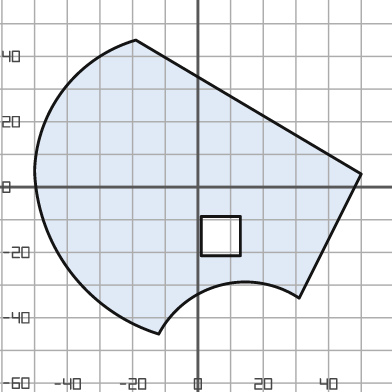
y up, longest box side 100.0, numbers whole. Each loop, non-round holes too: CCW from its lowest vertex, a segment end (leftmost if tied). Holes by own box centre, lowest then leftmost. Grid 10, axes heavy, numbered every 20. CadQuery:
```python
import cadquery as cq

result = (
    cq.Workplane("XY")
    .moveTo(-12.0, -45.0)
    .threePointArc((7.0, -30.0), (31.0, -34.0))
    .lineTo(50.0, 4.0)
    .lineTo(-19.0, 45.0)
    .threePointArc((-41.0, 30.0), (-50.0, 5.0))
    .threePointArc((-39.0, -26.0), (-12.0, -45.0))
    .close()
    .moveTo(1.0, -21.0)
    .lineTo(13.0, -21.0)
    .lineTo(13.0, -9.0)
    .lineTo(1.0, -9.0)
    .close()
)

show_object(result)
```